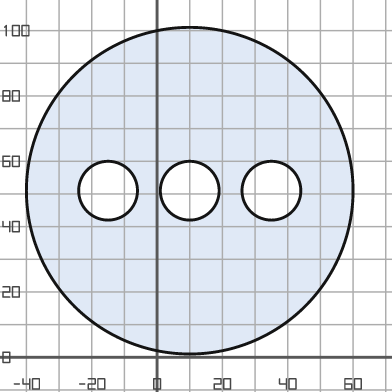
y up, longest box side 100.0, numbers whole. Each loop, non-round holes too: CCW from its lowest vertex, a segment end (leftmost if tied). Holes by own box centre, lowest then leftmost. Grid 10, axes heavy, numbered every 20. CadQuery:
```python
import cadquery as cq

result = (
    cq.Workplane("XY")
    .moveTo(10.0, 51.0)
    .circle(50.0)
    .moveTo(-15.0, 51.0)
    .circle(9.0)
    .moveTo(10.0, 51.0)
    .circle(9.0)
    .moveTo(35.0, 51.0)
    .circle(9.0)
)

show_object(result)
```